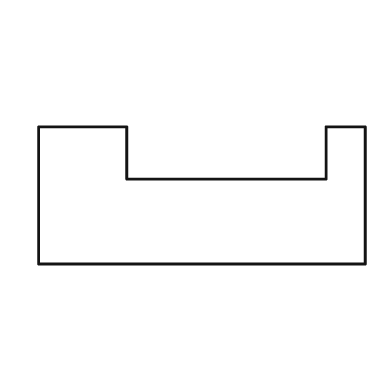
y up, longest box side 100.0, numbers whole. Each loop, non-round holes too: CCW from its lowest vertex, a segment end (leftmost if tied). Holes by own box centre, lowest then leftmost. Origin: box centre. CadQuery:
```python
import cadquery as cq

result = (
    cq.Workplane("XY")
    .moveTo(-50.0, -21.0)
    .lineTo(50.0, -21.0)
    .lineTo(50.0, 21.0)
    .lineTo(38.0, 21.0)
    .lineTo(38.0, 5.0)
    .lineTo(-23.0, 5.0)
    .lineTo(-23.0, 21.0)
    .lineTo(-50.0, 21.0)
    .close()
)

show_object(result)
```